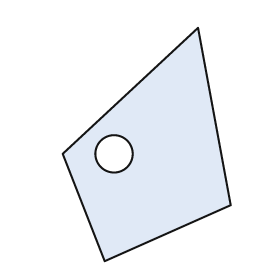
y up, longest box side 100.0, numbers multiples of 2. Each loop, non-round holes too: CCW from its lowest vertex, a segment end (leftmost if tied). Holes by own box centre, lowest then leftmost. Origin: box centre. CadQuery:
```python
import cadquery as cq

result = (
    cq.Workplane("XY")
    .moveTo(-18.0, -50.0)
    .lineTo(36.0, -26.0)
    .lineTo(22.0, 50.0)
    .lineTo(-36.0, -4.0)
    .close()
    .moveTo(-14.0, -4.0)
    .circle(8.0)
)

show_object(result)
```